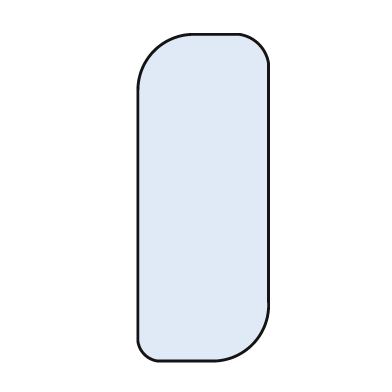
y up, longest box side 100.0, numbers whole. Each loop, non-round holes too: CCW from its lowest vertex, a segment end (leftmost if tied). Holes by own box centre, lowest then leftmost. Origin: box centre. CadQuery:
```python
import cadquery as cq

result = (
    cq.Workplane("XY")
    .moveTo(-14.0, -50.0)
    .lineTo(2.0, -50.0)
    .threePointArc((15.0, -45.0), (20.0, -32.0))
    .lineTo(20.0, 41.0)
    .threePointArc((17.0, 47.0), (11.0, 50.0))
    .lineTo(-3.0, 50.0)
    .threePointArc((-15.0, 45.0), (-20.0, 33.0))
    .lineTo(-20.0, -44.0)
    .threePointArc((-18.0, -48.0), (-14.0, -50.0))
    .close()
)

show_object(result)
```